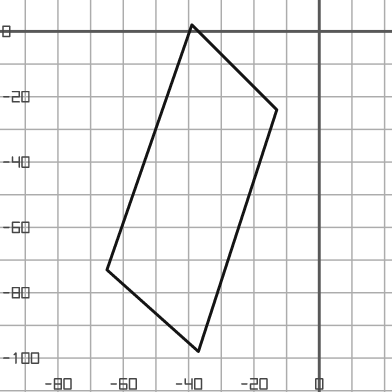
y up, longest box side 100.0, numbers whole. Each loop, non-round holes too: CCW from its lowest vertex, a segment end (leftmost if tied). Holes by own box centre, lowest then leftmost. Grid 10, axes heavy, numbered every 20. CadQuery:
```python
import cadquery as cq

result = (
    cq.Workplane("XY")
    .moveTo(-37.0, -98.0)
    .lineTo(-13.0, -24.0)
    .lineTo(-39.0, 2.0)
    .lineTo(-65.0, -73.0)
    .close()
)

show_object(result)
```